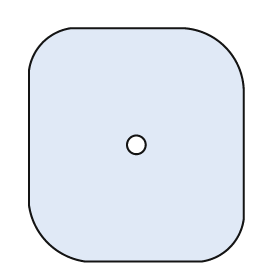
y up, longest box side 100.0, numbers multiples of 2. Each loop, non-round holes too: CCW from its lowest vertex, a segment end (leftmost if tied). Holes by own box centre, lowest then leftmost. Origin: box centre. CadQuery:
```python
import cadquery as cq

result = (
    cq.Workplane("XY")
    .moveTo(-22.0, -50.0)
    .lineTo(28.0, -50.0)
    .threePointArc((40.0, -44.0), (46.0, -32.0))
    .lineTo(46.0, 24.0)
    .threePointArc((38.0, 42.0), (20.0, 50.0))
    .lineTo(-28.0, 50.0)
    .threePointArc((-40.0, 44.0), (-46.0, 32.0))
    .lineTo(-46.0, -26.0)
    .threePointArc((-38.0, -42.0), (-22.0, -50.0))
    .close()
    .moveTo(0.0, 0.0)
    .circle(4.0)
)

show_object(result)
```